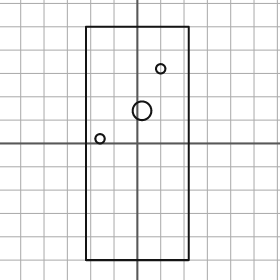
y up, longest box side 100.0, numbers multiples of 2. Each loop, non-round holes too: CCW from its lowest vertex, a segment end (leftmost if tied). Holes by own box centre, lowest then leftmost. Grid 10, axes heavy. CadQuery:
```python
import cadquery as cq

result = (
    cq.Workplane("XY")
    .moveTo(-22.0, -50.0)
    .lineTo(22.0, -50.0)
    .lineTo(22.0, 50.0)
    .lineTo(-22.0, 50.0)
    .close()
    .moveTo(-16.0, 2.0)
    .circle(2.0)
    .moveTo(2.0, 14.0)
    .circle(4.0)
    .moveTo(10.0, 32.0)
    .circle(2.0)
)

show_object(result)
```